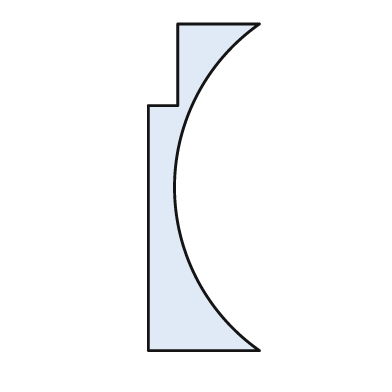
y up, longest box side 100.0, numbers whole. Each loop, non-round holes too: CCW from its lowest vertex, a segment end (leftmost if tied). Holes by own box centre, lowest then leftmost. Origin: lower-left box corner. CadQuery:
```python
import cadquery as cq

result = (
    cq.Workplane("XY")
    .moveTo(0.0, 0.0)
    .lineTo(34.0, 0.0)
    .threePointArc((8.0, 50.0), (34.0, 100.0))
    .lineTo(9.0, 100.0)
    .lineTo(9.0, 75.0)
    .lineTo(0.0, 75.0)
    .close()
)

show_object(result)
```